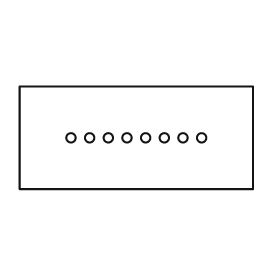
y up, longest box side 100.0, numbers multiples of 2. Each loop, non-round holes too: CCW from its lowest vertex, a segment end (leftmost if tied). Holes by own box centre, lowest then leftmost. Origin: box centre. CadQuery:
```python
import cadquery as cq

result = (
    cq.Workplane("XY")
    .moveTo(-50.0, -22.0)
    .lineTo(50.0, -22.0)
    .lineTo(50.0, 22.0)
    .lineTo(-50.0, 22.0)
    .close()
    .moveTo(-28.0, 0.0)
    .circle(2.0)
    .moveTo(-20.0, 0.0)
    .circle(2.0)
    .moveTo(-12.0, 0.0)
    .circle(2.0)
    .moveTo(-4.0, 0.0)
    .circle(2.0)
    .moveTo(4.0, 0.0)
    .circle(2.0)
    .moveTo(12.0, 0.0)
    .circle(2.0)
    .moveTo(20.0, 0.0)
    .circle(2.0)
    .moveTo(28.0, 0.0)
    .circle(2.0)
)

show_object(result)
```